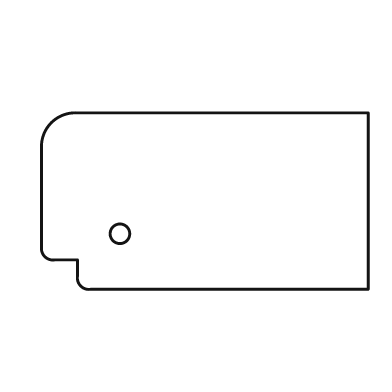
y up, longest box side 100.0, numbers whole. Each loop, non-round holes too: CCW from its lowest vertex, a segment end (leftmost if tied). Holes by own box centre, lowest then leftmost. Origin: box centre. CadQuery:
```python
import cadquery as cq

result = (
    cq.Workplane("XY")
    .moveTo(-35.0, -27.0)
    .lineTo(50.0, -27.0)
    .lineTo(50.0, 27.0)
    .lineTo(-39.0, 27.0)
    .threePointArc((-47.0, 24.0), (-50.0, 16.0))
    .lineTo(-50.0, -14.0)
    .threePointArc((-49.0, -17.0), (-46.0, -18.0))
    .lineTo(-39.0, -18.0)
    .lineTo(-39.0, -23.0)
    .threePointArc((-38.0, -26.0), (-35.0, -27.0))
    .close()
    .moveTo(-26.0, -10.0)
    .circle(3.0)
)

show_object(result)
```